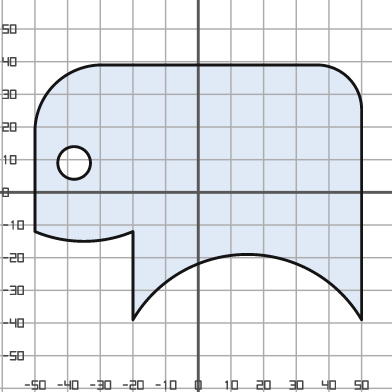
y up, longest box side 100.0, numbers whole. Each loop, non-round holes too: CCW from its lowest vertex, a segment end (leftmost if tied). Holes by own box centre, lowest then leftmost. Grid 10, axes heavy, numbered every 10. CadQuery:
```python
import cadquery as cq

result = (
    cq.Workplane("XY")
    .moveTo(-20.0, -39.0)
    .threePointArc((15.0, -19.0), (50.0, -39.0))
    .lineTo(50.0, 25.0)
    .threePointArc((46.0, 35.0), (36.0, 39.0))
    .lineTo(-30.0, 39.0)
    .threePointArc((-44.0, 33.0), (-50.0, 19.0))
    .lineTo(-50.0, -12.0)
    .threePointArc((-35.0, -15.0), (-20.0, -12.0))
    .close()
    .moveTo(-38.0, 9.0)
    .circle(5.0)
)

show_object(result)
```